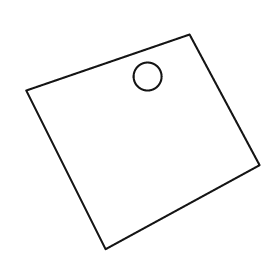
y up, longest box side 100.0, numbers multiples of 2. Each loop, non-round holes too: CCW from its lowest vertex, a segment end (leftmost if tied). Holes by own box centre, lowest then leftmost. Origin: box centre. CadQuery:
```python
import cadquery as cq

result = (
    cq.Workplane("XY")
    .moveTo(-16.0, -46.0)
    .lineTo(50.0, -10.0)
    .lineTo(20.0, 46.0)
    .lineTo(-50.0, 22.0)
    .close()
    .moveTo(2.0, 28.0)
    .circle(6.0)
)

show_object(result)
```